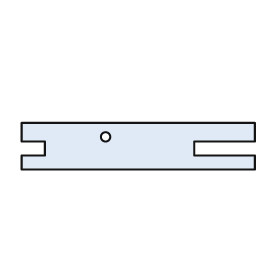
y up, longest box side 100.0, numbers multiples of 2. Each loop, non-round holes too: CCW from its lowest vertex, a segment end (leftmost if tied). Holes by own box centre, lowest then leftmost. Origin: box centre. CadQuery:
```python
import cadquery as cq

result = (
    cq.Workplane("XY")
    .moveTo(-50.0, -10.0)
    .lineTo(50.0, -10.0)
    .lineTo(50.0, -4.0)
    .lineTo(24.0, -4.0)
    .lineTo(24.0, 2.0)
    .lineTo(50.0, 2.0)
    .lineTo(50.0, 10.0)
    .lineTo(-50.0, 10.0)
    .lineTo(-50.0, 2.0)
    .lineTo(-40.0, 2.0)
    .lineTo(-40.0, -4.0)
    .lineTo(-50.0, -4.0)
    .close()
    .moveTo(-14.0, 4.0)
    .circle(2.0)
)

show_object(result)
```